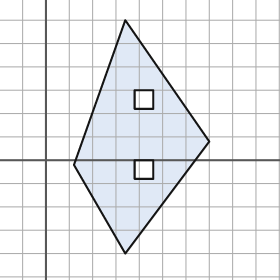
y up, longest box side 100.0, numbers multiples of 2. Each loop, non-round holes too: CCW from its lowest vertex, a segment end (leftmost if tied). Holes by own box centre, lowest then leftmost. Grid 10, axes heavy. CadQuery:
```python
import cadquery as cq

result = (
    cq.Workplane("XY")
    .moveTo(34.0, -40.0)
    .lineTo(70.0, 8.0)
    .lineTo(34.0, 60.0)
    .lineTo(12.0, -2.0)
    .close()
    .moveTo(38.0, -8.0)
    .lineTo(46.0, -8.0)
    .lineTo(46.0, 0.0)
    .lineTo(38.0, 0.0)
    .close()
    .moveTo(38.0, 22.0)
    .lineTo(46.0, 22.0)
    .lineTo(46.0, 30.0)
    .lineTo(38.0, 30.0)
    .close()
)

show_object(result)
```